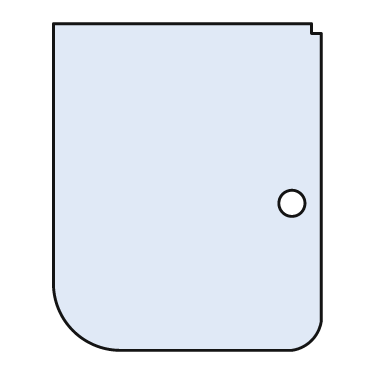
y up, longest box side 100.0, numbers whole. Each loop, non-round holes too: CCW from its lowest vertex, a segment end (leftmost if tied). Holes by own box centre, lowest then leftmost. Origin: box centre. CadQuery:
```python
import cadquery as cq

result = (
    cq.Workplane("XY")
    .moveTo(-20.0, -50.0)
    .lineTo(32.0, -50.0)
    .threePointArc((38.0, -47.0), (41.0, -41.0))
    .lineTo(41.0, 47.0)
    .lineTo(38.0, 47.0)
    .lineTo(38.0, 50.0)
    .lineTo(-41.0, 50.0)
    .lineTo(-41.0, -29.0)
    .threePointArc((-35.0, -44.0), (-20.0, -50.0))
    .close()
    .moveTo(32.0, -5.0)
    .circle(4.0)
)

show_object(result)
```